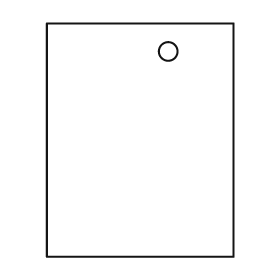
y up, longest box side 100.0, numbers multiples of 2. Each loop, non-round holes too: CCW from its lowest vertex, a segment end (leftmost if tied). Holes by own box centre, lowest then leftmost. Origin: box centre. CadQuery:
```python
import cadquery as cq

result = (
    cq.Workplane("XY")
    .moveTo(-40.0, -50.0)
    .lineTo(40.0, -50.0)
    .lineTo(40.0, 50.0)
    .lineTo(-40.0, 50.0)
    .close()
    .moveTo(12.0, 38.0)
    .circle(4.0)
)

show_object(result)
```